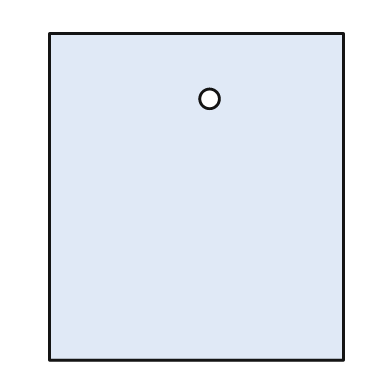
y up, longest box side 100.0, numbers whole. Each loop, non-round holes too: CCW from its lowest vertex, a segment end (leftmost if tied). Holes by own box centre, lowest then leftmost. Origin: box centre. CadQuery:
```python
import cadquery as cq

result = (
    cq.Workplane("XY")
    .moveTo(-45.0, -50.0)
    .lineTo(45.0, -50.0)
    .lineTo(45.0, 50.0)
    .lineTo(-45.0, 50.0)
    .close()
    .moveTo(4.0, 30.0)
    .circle(3.0)
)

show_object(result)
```